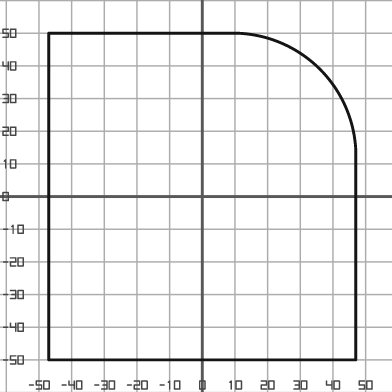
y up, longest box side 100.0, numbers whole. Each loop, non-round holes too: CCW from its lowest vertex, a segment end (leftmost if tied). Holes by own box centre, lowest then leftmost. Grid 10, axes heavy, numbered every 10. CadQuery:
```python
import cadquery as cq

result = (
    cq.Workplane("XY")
    .moveTo(-47.0, -50.0)
    .lineTo(47.0, -50.0)
    .lineTo(47.0, 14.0)
    .threePointArc((36.0, 39.0), (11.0, 50.0))
    .lineTo(-47.0, 50.0)
    .close()
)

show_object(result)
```